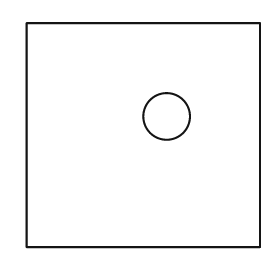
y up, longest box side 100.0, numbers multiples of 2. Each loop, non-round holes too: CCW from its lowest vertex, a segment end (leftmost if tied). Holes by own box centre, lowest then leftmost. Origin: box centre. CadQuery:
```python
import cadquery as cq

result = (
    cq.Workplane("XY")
    .moveTo(-50.0, -48.0)
    .lineTo(50.0, -48.0)
    .lineTo(50.0, 48.0)
    .lineTo(-50.0, 48.0)
    .close()
    .moveTo(10.0, 8.0)
    .circle(10.0)
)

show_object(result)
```